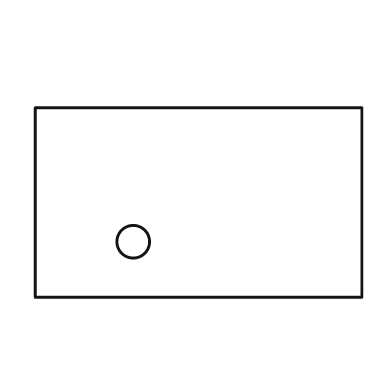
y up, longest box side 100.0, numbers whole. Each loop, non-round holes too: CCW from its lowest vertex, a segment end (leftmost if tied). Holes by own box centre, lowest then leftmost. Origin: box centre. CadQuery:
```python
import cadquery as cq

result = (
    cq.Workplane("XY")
    .moveTo(-50.0, -29.0)
    .lineTo(50.0, -29.0)
    .lineTo(50.0, 29.0)
    .lineTo(-50.0, 29.0)
    .close()
    .moveTo(-20.0, -12.0)
    .circle(5.0)
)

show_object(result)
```